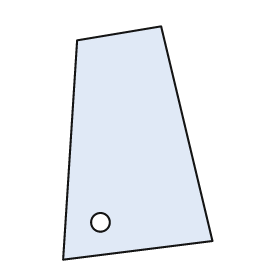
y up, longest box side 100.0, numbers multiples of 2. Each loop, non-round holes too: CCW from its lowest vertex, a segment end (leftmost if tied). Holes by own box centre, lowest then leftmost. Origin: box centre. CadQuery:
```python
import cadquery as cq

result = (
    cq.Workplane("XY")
    .moveTo(-32.0, -50.0)
    .lineTo(32.0, -42.0)
    .lineTo(10.0, 50.0)
    .lineTo(-26.0, 44.0)
    .close()
    .moveTo(-16.0, -34.0)
    .circle(4.0)
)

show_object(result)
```